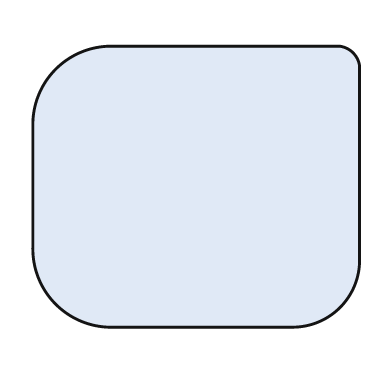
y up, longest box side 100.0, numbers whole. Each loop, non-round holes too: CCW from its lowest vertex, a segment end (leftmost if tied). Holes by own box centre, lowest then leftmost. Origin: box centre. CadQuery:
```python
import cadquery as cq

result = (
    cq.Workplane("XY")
    .moveTo(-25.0, -43.0)
    .lineTo(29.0, -43.0)
    .threePointArc((44.0, -37.0), (50.0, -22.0))
    .lineTo(50.0, 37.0)
    .threePointArc((48.0, 41.0), (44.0, 43.0))
    .lineTo(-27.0, 43.0)
    .threePointArc((-43.0, 36.0), (-50.0, 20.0))
    .lineTo(-50.0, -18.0)
    .threePointArc((-43.0, -36.0), (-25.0, -43.0))
    .close()
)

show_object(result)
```